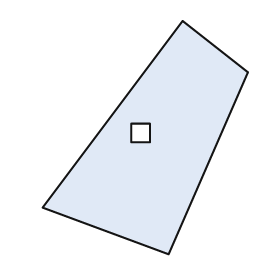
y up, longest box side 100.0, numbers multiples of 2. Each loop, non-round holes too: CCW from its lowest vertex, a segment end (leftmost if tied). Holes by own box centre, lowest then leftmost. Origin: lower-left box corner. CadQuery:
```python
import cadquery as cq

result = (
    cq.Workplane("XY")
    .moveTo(54.0, 0.0)
    .lineTo(88.0, 78.0)
    .lineTo(60.0, 100.0)
    .lineTo(0.0, 20.0)
    .close()
    .moveTo(38.0, 48.0)
    .lineTo(46.0, 48.0)
    .lineTo(46.0, 56.0)
    .lineTo(38.0, 56.0)
    .close()
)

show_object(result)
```